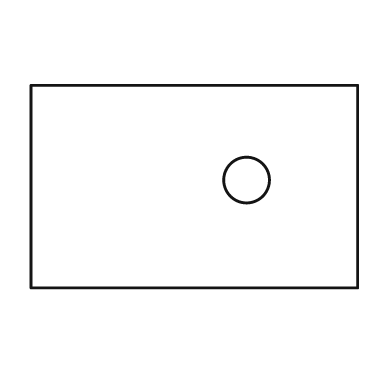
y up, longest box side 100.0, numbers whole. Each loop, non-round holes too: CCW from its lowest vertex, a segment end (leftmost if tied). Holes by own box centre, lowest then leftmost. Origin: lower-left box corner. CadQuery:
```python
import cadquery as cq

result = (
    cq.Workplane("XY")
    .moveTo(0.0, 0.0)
    .lineTo(100.0, 0.0)
    .lineTo(100.0, 62.0)
    .lineTo(0.0, 62.0)
    .close()
    .moveTo(66.0, 33.0)
    .circle(7.0)
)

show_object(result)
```